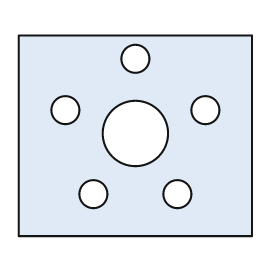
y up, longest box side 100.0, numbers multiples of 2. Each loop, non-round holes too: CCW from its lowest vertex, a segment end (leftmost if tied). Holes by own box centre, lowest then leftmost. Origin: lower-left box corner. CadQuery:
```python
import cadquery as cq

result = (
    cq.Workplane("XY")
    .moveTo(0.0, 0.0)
    .lineTo(100.0, 0.0)
    .lineTo(100.0, 86.0)
    .lineTo(0.0, 86.0)
    .close()
    .moveTo(32.0, 18.0)
    .circle(6.0)
    .moveTo(68.0, 18.0)
    .circle(6.0)
    .moveTo(50.0, 44.0)
    .circle(14.0)
    .moveTo(20.0, 54.0)
    .circle(6.0)
    .moveTo(80.0, 54.0)
    .circle(6.0)
    .moveTo(50.0, 76.0)
    .circle(6.0)
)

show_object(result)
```